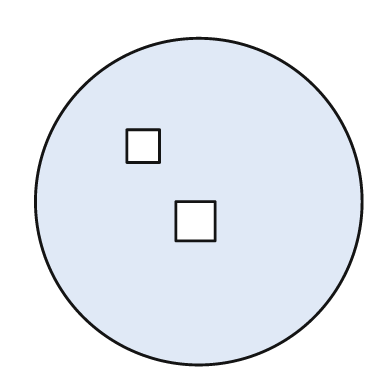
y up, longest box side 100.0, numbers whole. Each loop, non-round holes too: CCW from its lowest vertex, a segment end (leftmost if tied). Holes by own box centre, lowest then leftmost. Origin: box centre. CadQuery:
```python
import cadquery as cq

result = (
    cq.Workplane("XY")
    .moveTo(0.0, 0.0)
    .circle(50.0)
    .moveTo(-7.0, -12.0)
    .lineTo(5.0, -12.0)
    .lineTo(5.0, 0.0)
    .lineTo(-7.0, 0.0)
    .close()
    .moveTo(-22.0, 12.0)
    .lineTo(-12.0, 12.0)
    .lineTo(-12.0, 22.0)
    .lineTo(-22.0, 22.0)
    .close()
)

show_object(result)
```